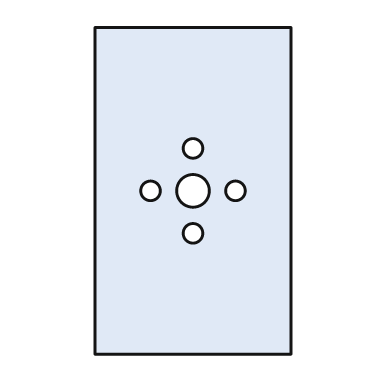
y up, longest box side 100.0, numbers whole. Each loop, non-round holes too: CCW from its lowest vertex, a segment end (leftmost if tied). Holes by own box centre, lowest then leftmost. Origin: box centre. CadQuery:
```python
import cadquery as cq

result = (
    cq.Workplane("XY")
    .moveTo(-30.0, -50.0)
    .lineTo(30.0, -50.0)
    .lineTo(30.0, 50.0)
    .lineTo(-30.0, 50.0)
    .close()
    .moveTo(0.0, -13.0)
    .circle(3.0)
    .moveTo(-13.0, 0.0)
    .circle(3.0)
    .moveTo(0.0, 0.0)
    .circle(5.0)
    .moveTo(13.0, 0.0)
    .circle(3.0)
    .moveTo(0.0, 13.0)
    .circle(3.0)
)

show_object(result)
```